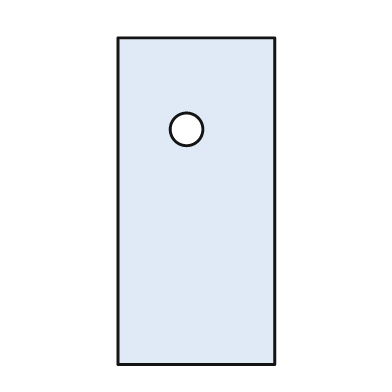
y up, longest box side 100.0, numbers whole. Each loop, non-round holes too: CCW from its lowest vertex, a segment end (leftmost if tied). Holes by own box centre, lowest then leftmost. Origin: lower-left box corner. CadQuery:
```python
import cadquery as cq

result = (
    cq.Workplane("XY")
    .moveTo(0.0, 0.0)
    .lineTo(48.0, 0.0)
    .lineTo(48.0, 100.0)
    .lineTo(0.0, 100.0)
    .close()
    .moveTo(21.0, 72.0)
    .circle(5.0)
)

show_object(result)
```